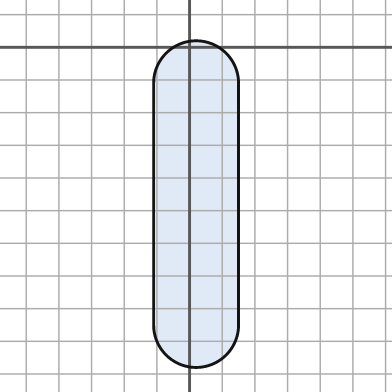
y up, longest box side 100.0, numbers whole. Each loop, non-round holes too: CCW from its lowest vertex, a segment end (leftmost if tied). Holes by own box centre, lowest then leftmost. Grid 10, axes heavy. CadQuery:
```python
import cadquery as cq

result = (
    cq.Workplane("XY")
    .moveTo(-11.0, -85.0)
    .threePointArc((2.0, -98.0), (15.0, -85.0))
    .lineTo(15.0, -11.0)
    .threePointArc((2.0, 2.0), (-11.0, -11.0))
    .close()
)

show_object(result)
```